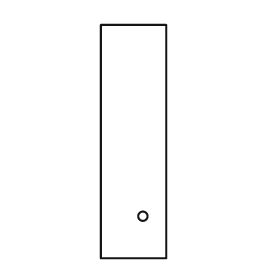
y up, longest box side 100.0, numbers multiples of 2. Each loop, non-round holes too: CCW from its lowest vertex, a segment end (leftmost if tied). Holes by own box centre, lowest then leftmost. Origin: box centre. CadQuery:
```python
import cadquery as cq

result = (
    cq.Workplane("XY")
    .moveTo(-14.0, -50.0)
    .lineTo(14.0, -50.0)
    .lineTo(14.0, 50.0)
    .lineTo(-14.0, 50.0)
    .close()
    .moveTo(4.0, -32.0)
    .circle(2.0)
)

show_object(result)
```